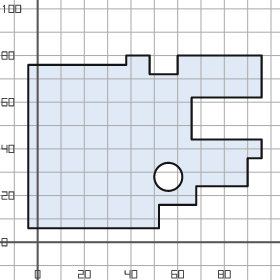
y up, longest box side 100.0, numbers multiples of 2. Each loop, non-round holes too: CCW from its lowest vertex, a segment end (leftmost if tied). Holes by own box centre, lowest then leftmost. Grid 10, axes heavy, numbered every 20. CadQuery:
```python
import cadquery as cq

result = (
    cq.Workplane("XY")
    .moveTo(-4.0, 6.0)
    .lineTo(52.0, 6.0)
    .lineTo(52.0, 16.0)
    .lineTo(68.0, 16.0)
    .lineTo(68.0, 24.0)
    .lineTo(90.0, 24.0)
    .lineTo(90.0, 36.0)
    .lineTo(96.0, 36.0)
    .lineTo(96.0, 44.0)
    .lineTo(66.0, 44.0)
    .lineTo(66.0, 62.0)
    .lineTo(96.0, 62.0)
    .lineTo(96.0, 80.0)
    .lineTo(60.0, 80.0)
    .lineTo(60.0, 72.0)
    .lineTo(48.0, 72.0)
    .lineTo(48.0, 80.0)
    .lineTo(38.0, 80.0)
    .lineTo(38.0, 76.0)
    .lineTo(-4.0, 76.0)
    .close()
    .moveTo(56.0, 28.0)
    .circle(6.0)
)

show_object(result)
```